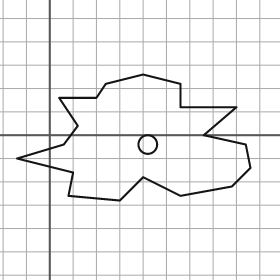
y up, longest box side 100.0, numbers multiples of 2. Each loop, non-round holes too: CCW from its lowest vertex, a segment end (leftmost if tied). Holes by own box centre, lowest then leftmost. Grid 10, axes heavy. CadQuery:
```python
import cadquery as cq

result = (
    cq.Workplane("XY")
    .moveTo(30.0, -28.0)
    .lineTo(40.0, -18.0)
    .lineTo(56.0, -26.0)
    .lineTo(78.0, -22.0)
    .lineTo(86.0, -14.0)
    .lineTo(84.0, -4.0)
    .lineTo(66.0, 0.0)
    .lineTo(80.0, 12.0)
    .lineTo(56.0, 12.0)
    .lineTo(56.0, 22.0)
    .lineTo(40.0, 26.0)
    .lineTo(24.0, 22.0)
    .lineTo(20.0, 16.0)
    .lineTo(4.0, 16.0)
    .lineTo(12.0, 4.0)
    .lineTo(6.0, -4.0)
    .lineTo(-14.0, -10.0)
    .lineTo(10.0, -16.0)
    .lineTo(8.0, -26.0)
    .close()
    .moveTo(42.0, -4.0)
    .circle(4.0)
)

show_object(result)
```